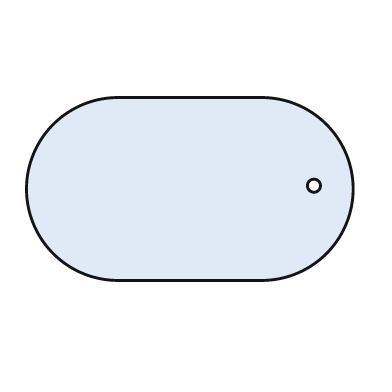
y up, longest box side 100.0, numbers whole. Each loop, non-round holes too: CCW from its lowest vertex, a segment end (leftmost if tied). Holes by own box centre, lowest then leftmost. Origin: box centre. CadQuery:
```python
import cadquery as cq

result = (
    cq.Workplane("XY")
    .moveTo(-22.0, -28.0)
    .lineTo(22.0, -28.0)
    .threePointArc((50.0, 0.0), (22.0, 28.0))
    .lineTo(-22.0, 28.0)
    .threePointArc((-50.0, 0.0), (-22.0, -28.0))
    .close()
    .moveTo(38.0, 1.0)
    .circle(2.0)
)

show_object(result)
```